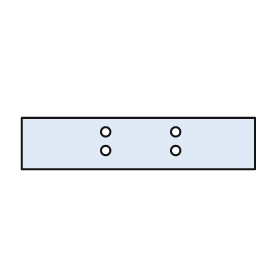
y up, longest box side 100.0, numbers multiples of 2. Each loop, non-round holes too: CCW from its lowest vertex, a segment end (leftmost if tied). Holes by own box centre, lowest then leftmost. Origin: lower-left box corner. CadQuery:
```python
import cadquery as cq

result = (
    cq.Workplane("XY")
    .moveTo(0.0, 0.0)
    .lineTo(100.0, 0.0)
    .lineTo(100.0, 22.0)
    .lineTo(0.0, 22.0)
    .close()
    .moveTo(36.0, 8.0)
    .circle(2.0)
    .moveTo(66.0, 8.0)
    .circle(2.0)
    .moveTo(36.0, 16.0)
    .circle(2.0)
    .moveTo(66.0, 16.0)
    .circle(2.0)
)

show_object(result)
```